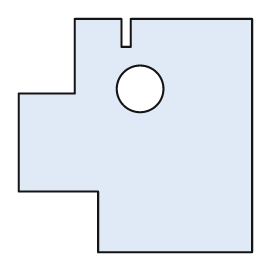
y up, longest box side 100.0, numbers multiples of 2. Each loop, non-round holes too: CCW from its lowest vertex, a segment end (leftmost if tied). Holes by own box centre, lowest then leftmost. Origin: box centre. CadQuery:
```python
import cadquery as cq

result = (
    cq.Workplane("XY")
    .moveTo(-16.0, -50.0)
    .lineTo(50.0, -50.0)
    .lineTo(50.0, 50.0)
    .lineTo(-2.0, 50.0)
    .lineTo(-2.0, 38.0)
    .lineTo(-6.0, 38.0)
    .lineTo(-6.0, 50.0)
    .lineTo(-26.0, 50.0)
    .lineTo(-26.0, 18.0)
    .lineTo(-50.0, 18.0)
    .lineTo(-50.0, -24.0)
    .lineTo(-16.0, -24.0)
    .close()
    .moveTo(2.0, 20.0)
    .circle(10.0)
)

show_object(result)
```